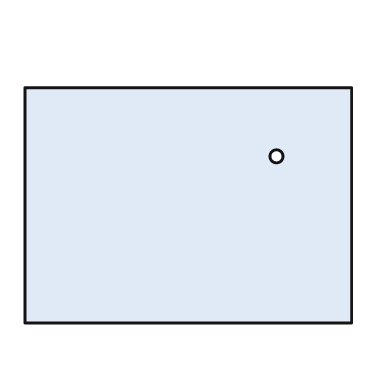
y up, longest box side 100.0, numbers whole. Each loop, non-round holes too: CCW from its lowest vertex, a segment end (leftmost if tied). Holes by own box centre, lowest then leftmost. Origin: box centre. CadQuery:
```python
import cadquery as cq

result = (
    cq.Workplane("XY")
    .moveTo(-50.0, -36.0)
    .lineTo(50.0, -36.0)
    .lineTo(50.0, 36.0)
    .lineTo(-50.0, 36.0)
    .close()
    .moveTo(27.0, 15.0)
    .circle(2.0)
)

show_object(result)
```